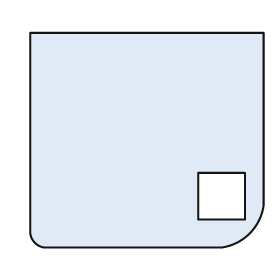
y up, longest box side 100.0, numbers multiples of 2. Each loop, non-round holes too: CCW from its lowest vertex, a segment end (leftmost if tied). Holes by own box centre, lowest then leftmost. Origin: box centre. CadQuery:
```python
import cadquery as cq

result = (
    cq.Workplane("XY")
    .moveTo(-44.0, -46.0)
    .lineTo(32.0, -46.0)
    .threePointArc((44.0, -40.0), (50.0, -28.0))
    .lineTo(50.0, 46.0)
    .lineTo(-50.0, 46.0)
    .lineTo(-50.0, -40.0)
    .threePointArc((-48.0, -44.0), (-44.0, -46.0))
    .close()
    .moveTo(22.0, -34.0)
    .lineTo(42.0, -34.0)
    .lineTo(42.0, -14.0)
    .lineTo(22.0, -14.0)
    .close()
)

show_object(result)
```